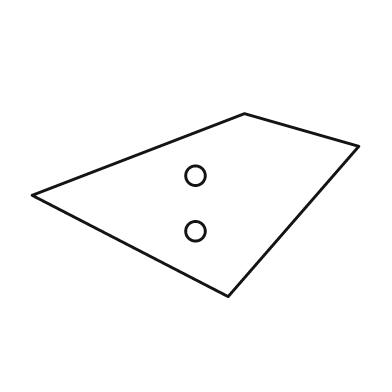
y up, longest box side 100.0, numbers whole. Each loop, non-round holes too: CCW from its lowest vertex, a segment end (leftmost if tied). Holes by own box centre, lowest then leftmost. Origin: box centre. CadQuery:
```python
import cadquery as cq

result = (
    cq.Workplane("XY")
    .moveTo(10.0, -28.0)
    .lineTo(50.0, 18.0)
    .lineTo(15.0, 28.0)
    .lineTo(-50.0, 3.0)
    .close()
    .moveTo(0.0, -8.0)
    .circle(3.0)
    .moveTo(0.0, 9.0)
    .circle(3.0)
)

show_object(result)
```